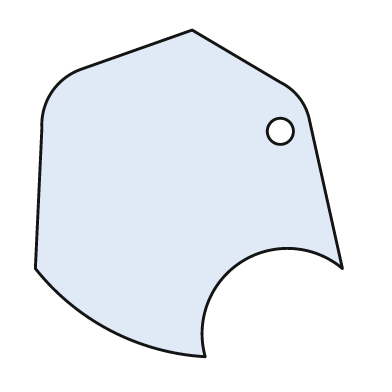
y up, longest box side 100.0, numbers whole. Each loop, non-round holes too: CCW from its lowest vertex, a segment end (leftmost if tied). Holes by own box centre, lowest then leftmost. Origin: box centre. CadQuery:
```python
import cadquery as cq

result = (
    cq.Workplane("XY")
    .moveTo(5.0, -50.0)
    .threePointArc((16.0, -21.0), (47.0, -23.0))
    .lineTo(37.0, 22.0)
    .threePointArc((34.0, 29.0), (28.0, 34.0))
    .lineTo(1.0, 50.0)
    .lineTo(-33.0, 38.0)
    .threePointArc((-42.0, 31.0), (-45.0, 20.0))
    .lineTo(-47.0, -23.0)
    .threePointArc((-24.0, -42.0), (5.0, -50.0))
    .close()
    .moveTo(28.0, 19.0)
    .circle(4.0)
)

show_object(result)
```